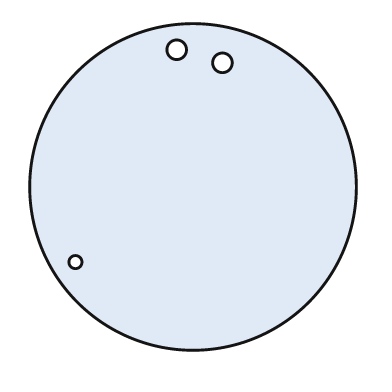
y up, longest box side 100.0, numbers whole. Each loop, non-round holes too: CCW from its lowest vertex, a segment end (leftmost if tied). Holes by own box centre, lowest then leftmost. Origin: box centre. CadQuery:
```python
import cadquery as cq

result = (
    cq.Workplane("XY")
    .moveTo(0.0, 0.0)
    .circle(50.0)
    .moveTo(-36.0, -23.0)
    .circle(2.0)
    .moveTo(9.0, 38.0)
    .circle(3.0)
    .moveTo(-5.0, 42.0)
    .circle(3.0)
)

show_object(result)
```